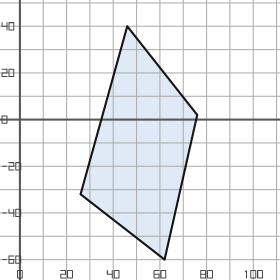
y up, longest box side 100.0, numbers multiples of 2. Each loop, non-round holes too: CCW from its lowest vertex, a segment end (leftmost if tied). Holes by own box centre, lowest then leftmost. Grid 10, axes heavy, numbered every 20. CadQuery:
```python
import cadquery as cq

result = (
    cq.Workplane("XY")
    .moveTo(62.0, -60.0)
    .lineTo(76.0, 2.0)
    .lineTo(46.0, 40.0)
    .lineTo(26.0, -32.0)
    .close()
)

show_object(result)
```